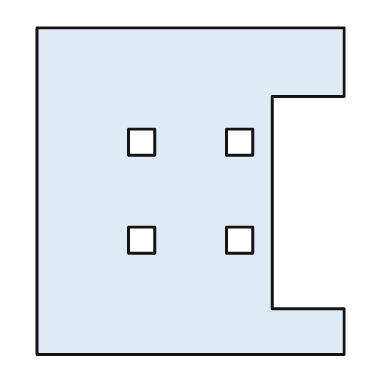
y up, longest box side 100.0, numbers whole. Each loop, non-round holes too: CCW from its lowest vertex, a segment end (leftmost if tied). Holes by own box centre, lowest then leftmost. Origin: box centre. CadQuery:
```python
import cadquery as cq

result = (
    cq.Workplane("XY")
    .moveTo(-47.0, -50.0)
    .lineTo(47.0, -50.0)
    .lineTo(47.0, -36.0)
    .lineTo(25.0, -36.0)
    .lineTo(25.0, 29.0)
    .lineTo(47.0, 29.0)
    .lineTo(47.0, 50.0)
    .lineTo(-47.0, 50.0)
    .close()
    .moveTo(-19.0, -19.0)
    .lineTo(-11.0, -19.0)
    .lineTo(-11.0, -11.0)
    .lineTo(-19.0, -11.0)
    .close()
    .moveTo(11.0, -19.0)
    .lineTo(19.0, -19.0)
    .lineTo(19.0, -11.0)
    .lineTo(11.0, -11.0)
    .close()
    .moveTo(-19.0, 11.0)
    .lineTo(-11.0, 11.0)
    .lineTo(-11.0, 19.0)
    .lineTo(-19.0, 19.0)
    .close()
    .moveTo(11.0, 11.0)
    .lineTo(19.0, 11.0)
    .lineTo(19.0, 19.0)
    .lineTo(11.0, 19.0)
    .close()
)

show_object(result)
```